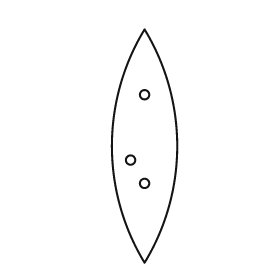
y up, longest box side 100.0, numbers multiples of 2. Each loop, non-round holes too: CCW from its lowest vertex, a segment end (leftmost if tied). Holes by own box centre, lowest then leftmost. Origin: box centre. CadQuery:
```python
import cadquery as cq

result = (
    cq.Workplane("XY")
    .moveTo(0.0, -50.0)
    .threePointArc((14.0, 0.0), (0.0, 50.0))
    .threePointArc((-14.0, 0.0), (0.0, -50.0))
    .close()
    .moveTo(0.0, -16.0)
    .circle(2.0)
    .moveTo(-6.0, -6.0)
    .circle(2.0)
    .moveTo(0.0, 22.0)
    .circle(2.0)
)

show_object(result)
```